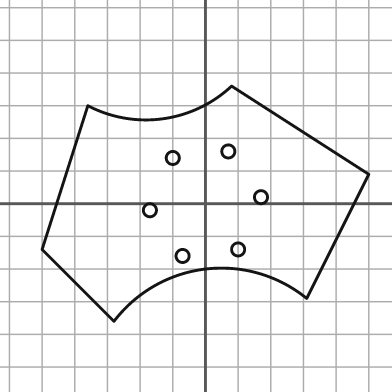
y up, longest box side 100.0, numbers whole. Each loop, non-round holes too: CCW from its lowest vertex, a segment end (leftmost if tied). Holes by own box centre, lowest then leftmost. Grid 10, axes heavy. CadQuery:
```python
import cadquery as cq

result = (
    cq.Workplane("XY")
    .moveTo(-28.0, -36.0)
    .threePointArc((0.0, -20.0), (31.0, -29.0))
    .lineTo(50.0, 9.0)
    .lineTo(8.0, 36.0)
    .threePointArc((-13.0, 26.0), (-36.0, 30.0))
    .lineTo(-50.0, -14.0)
    .close()
    .moveTo(-7.0, -16.0)
    .circle(2.0)
    .moveTo(10.0, -14.0)
    .circle(2.0)
    .moveTo(-17.0, -2.0)
    .circle(2.0)
    .moveTo(17.0, 2.0)
    .circle(2.0)
    .moveTo(-10.0, 14.0)
    .circle(2.0)
    .moveTo(7.0, 16.0)
    .circle(2.0)
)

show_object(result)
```